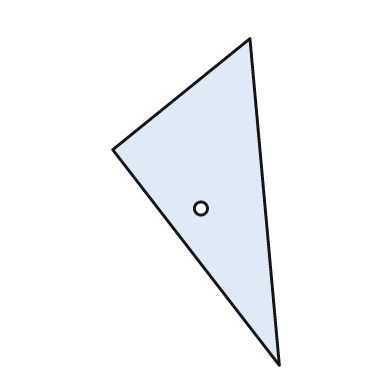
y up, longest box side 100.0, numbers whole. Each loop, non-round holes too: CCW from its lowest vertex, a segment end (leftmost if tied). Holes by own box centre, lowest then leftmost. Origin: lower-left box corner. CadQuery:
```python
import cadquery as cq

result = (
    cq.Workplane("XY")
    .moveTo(51.0, 0.0)
    .lineTo(42.0, 100.0)
    .lineTo(0.0, 66.0)
    .close()
    .moveTo(27.0, 48.0)
    .circle(2.0)
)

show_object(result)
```